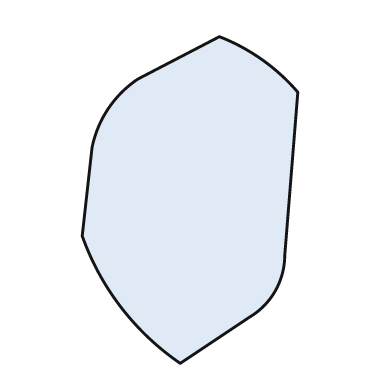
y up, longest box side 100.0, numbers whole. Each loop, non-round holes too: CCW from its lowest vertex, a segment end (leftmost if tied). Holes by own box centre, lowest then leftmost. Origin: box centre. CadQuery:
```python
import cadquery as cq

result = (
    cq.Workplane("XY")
    .moveTo(-3.0, -50.0)
    .lineTo(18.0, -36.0)
    .threePointArc((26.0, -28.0), (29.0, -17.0))
    .lineTo(33.0, 33.0)
    .threePointArc((22.0, 43.0), (9.0, 50.0))
    .lineTo(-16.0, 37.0)
    .threePointArc((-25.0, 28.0), (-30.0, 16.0))
    .lineTo(-33.0, -11.0)
    .threePointArc((-21.0, -33.0), (-3.0, -50.0))
    .close()
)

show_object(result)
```